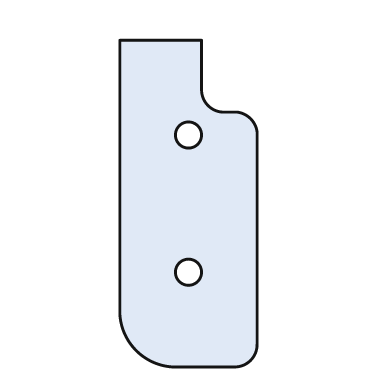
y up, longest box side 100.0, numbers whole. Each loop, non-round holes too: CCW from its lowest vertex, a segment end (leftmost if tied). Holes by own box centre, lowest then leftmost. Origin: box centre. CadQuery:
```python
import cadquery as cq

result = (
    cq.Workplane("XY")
    .moveTo(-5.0, -50.0)
    .lineTo(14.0, -50.0)
    .threePointArc((19.0, -48.0), (21.0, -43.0))
    .lineTo(21.0, 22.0)
    .threePointArc((19.0, 26.0), (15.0, 28.0))
    .lineTo(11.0, 28.0)
    .threePointArc((6.0, 30.0), (4.0, 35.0))
    .lineTo(4.0, 50.0)
    .lineTo(-21.0, 50.0)
    .lineTo(-21.0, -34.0)
    .threePointArc((-16.0, -45.0), (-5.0, -50.0))
    .close()
    .moveTo(0.0, -21.0)
    .circle(4.0)
    .moveTo(0.0, 21.0)
    .circle(4.0)
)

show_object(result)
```